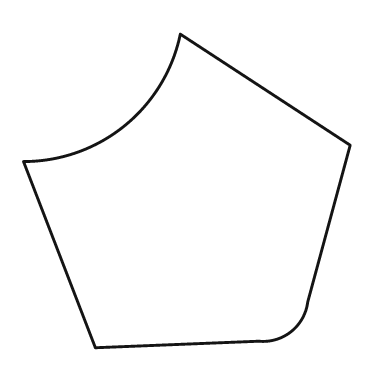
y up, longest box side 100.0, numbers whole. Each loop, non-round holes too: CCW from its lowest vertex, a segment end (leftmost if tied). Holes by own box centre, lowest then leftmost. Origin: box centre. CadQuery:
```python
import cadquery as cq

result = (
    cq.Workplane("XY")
    .moveTo(-28.0, -48.0)
    .lineTo(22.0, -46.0)
    .threePointArc((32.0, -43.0), (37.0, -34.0))
    .lineTo(50.0, 14.0)
    .lineTo(-2.0, 48.0)
    .threePointArc((-19.0, 20.0), (-50.0, 9.0))
    .close()
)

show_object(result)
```